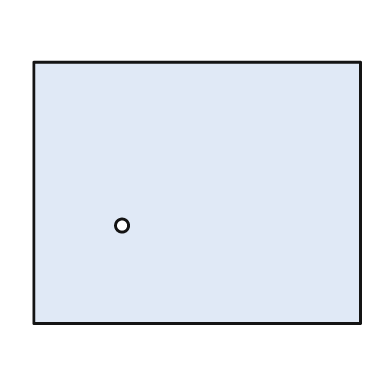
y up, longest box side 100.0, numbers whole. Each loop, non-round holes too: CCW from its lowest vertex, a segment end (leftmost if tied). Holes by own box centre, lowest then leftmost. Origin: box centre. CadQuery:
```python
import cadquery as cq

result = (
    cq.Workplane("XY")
    .moveTo(-50.0, -40.0)
    .lineTo(50.0, -40.0)
    .lineTo(50.0, 40.0)
    .lineTo(-50.0, 40.0)
    .close()
    .moveTo(-23.0, -10.0)
    .circle(2.0)
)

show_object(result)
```